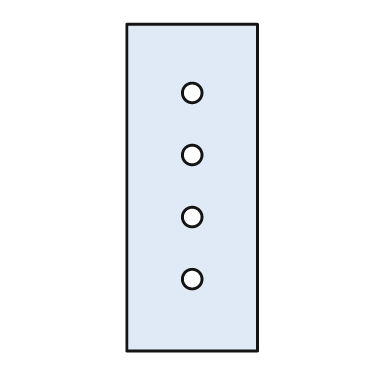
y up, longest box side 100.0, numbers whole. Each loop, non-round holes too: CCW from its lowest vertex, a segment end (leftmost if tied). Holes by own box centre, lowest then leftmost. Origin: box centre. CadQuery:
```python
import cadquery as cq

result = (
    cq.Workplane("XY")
    .moveTo(-20.0, -50.0)
    .lineTo(20.0, -50.0)
    .lineTo(20.0, 50.0)
    .lineTo(-20.0, 50.0)
    .close()
    .moveTo(0.0, -28.0)
    .circle(3.0)
    .moveTo(0.0, -9.0)
    .circle(3.0)
    .moveTo(0.0, 10.0)
    .circle(3.0)
    .moveTo(0.0, 29.0)
    .circle(3.0)
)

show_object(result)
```